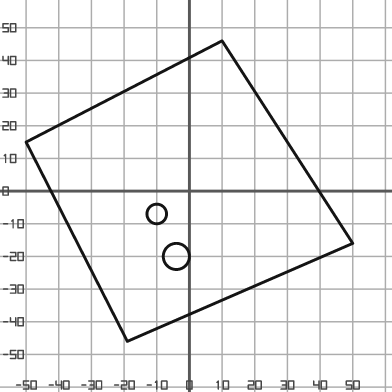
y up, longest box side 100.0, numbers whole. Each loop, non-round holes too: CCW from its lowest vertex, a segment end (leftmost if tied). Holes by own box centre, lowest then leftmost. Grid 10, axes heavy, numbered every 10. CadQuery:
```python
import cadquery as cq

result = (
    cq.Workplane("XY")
    .moveTo(-19.0, -46.0)
    .lineTo(50.0, -16.0)
    .lineTo(10.0, 46.0)
    .lineTo(-50.0, 15.0)
    .close()
    .moveTo(-4.0, -20.0)
    .circle(4.0)
    .moveTo(-10.0, -7.0)
    .circle(3.0)
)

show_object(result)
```